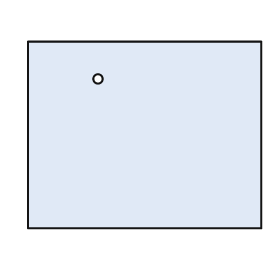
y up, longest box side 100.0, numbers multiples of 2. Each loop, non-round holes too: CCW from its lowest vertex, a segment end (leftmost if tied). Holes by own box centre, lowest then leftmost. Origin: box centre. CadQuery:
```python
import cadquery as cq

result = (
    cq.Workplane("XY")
    .moveTo(-50.0, -40.0)
    .lineTo(50.0, -40.0)
    .lineTo(50.0, 40.0)
    .lineTo(-50.0, 40.0)
    .close()
    .moveTo(-20.0, 24.0)
    .circle(2.0)
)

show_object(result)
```